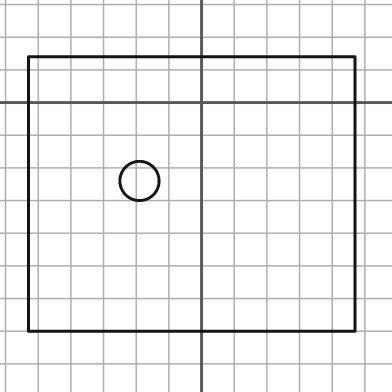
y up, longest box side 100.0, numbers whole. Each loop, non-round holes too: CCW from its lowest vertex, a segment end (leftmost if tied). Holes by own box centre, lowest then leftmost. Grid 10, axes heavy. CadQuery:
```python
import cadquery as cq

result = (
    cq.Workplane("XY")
    .moveTo(-53.0, -70.0)
    .lineTo(47.0, -70.0)
    .lineTo(47.0, 14.0)
    .lineTo(-53.0, 14.0)
    .close()
    .moveTo(-19.0, -24.0)
    .circle(6.0)
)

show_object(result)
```